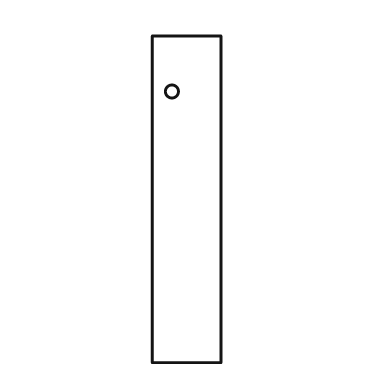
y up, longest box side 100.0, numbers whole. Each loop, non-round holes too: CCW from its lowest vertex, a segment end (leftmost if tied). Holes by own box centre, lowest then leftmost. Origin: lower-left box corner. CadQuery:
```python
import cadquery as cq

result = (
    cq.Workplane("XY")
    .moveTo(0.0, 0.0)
    .lineTo(21.0, 0.0)
    .lineTo(21.0, 100.0)
    .lineTo(0.0, 100.0)
    .close()
    .moveTo(6.0, 83.0)
    .circle(2.0)
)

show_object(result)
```